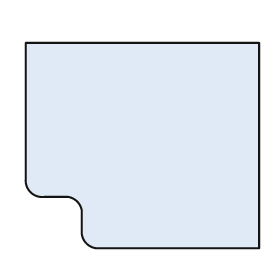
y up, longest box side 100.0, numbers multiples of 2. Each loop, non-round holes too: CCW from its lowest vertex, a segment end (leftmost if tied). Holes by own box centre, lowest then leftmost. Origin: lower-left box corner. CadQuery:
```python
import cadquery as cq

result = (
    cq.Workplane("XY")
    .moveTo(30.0, 0.0)
    .lineTo(100.0, 0.0)
    .lineTo(100.0, 88.0)
    .lineTo(0.0, 88.0)
    .lineTo(0.0, 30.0)
    .threePointArc((2.0, 24.0), (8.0, 22.0))
    .lineTo(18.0, 22.0)
    .threePointArc((22.0, 20.0), (24.0, 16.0))
    .lineTo(24.0, 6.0)
    .threePointArc((26.0, 2.0), (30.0, 0.0))
    .close()
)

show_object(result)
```